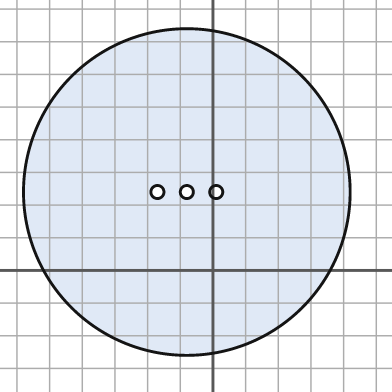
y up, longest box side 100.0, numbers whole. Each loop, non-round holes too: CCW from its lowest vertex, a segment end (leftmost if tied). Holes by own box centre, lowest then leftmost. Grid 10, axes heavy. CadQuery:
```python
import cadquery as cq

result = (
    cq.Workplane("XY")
    .moveTo(-8.0, 24.0)
    .circle(50.0)
    .moveTo(-17.0, 24.0)
    .circle(2.0)
    .moveTo(-8.0, 24.0)
    .circle(2.0)
    .moveTo(1.0, 24.0)
    .circle(2.0)
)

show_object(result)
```